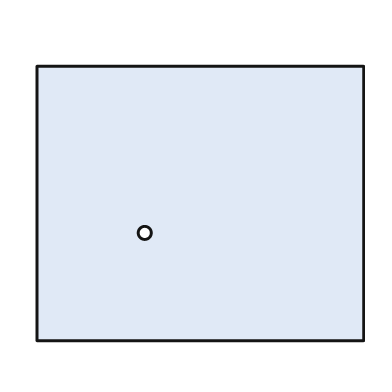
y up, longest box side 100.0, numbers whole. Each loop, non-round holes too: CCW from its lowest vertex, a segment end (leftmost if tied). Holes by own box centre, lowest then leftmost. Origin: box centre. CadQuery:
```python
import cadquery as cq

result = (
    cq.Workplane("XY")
    .moveTo(-50.0, -42.0)
    .lineTo(50.0, -42.0)
    .lineTo(50.0, 42.0)
    .lineTo(-50.0, 42.0)
    .close()
    .moveTo(-17.0, -9.0)
    .circle(2.0)
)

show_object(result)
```